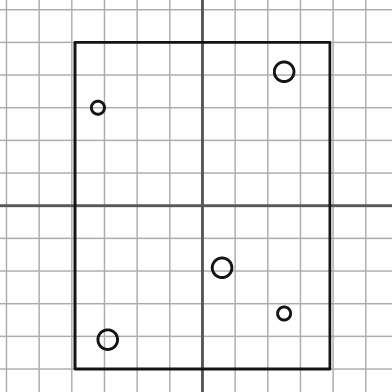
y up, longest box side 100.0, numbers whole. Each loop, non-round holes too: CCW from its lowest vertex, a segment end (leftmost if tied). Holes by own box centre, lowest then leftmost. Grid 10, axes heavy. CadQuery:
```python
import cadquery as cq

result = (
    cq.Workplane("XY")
    .moveTo(-39.0, -50.0)
    .lineTo(39.0, -50.0)
    .lineTo(39.0, 50.0)
    .lineTo(-39.0, 50.0)
    .close()
    .moveTo(-29.0, -41.0)
    .circle(3.0)
    .moveTo(25.0, -33.0)
    .circle(2.0)
    .moveTo(6.0, -19.0)
    .circle(3.0)
    .moveTo(-32.0, 30.0)
    .circle(2.0)
    .moveTo(25.0, 41.0)
    .circle(3.0)
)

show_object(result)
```